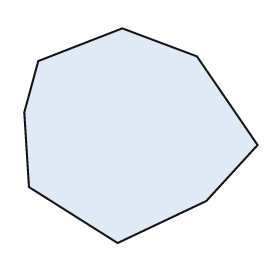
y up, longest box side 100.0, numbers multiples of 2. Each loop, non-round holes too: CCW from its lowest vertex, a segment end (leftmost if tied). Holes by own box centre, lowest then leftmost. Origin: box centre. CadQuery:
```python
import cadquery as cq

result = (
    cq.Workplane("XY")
    .moveTo(-10.0, -46.0)
    .lineTo(28.0, -28.0)
    .lineTo(50.0, -4.0)
    .lineTo(24.0, 34.0)
    .lineTo(-8.0, 46.0)
    .lineTo(-44.0, 32.0)
    .lineTo(-50.0, 10.0)
    .lineTo(-48.0, -22.0)
    .close()
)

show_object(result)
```